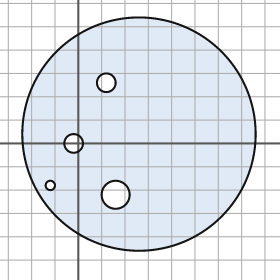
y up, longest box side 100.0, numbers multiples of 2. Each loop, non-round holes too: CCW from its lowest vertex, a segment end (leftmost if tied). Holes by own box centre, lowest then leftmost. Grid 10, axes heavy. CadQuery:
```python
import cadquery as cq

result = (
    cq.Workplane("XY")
    .moveTo(26.0, 4.0)
    .circle(50.0)
    .moveTo(16.0, -22.0)
    .circle(6.0)
    .moveTo(-12.0, -18.0)
    .circle(2.0)
    .moveTo(-2.0, 0.0)
    .circle(4.0)
    .moveTo(12.0, 26.0)
    .circle(4.0)
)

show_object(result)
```